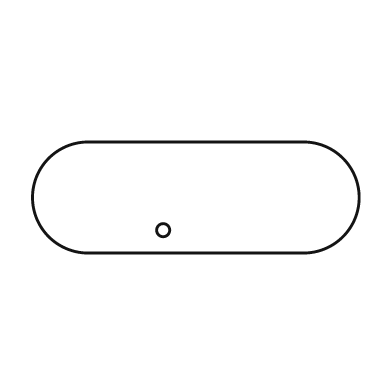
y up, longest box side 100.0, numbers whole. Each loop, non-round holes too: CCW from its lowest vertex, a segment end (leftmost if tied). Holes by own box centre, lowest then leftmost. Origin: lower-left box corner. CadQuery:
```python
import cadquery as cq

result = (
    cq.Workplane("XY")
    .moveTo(17.0, 0.0)
    .lineTo(83.0, 0.0)
    .threePointArc((100.0, 17.0), (83.0, 34.0))
    .lineTo(17.0, 34.0)
    .threePointArc((0.0, 17.0), (17.0, 0.0))
    .close()
    .moveTo(40.0, 7.0)
    .circle(2.0)
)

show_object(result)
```